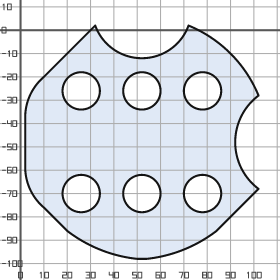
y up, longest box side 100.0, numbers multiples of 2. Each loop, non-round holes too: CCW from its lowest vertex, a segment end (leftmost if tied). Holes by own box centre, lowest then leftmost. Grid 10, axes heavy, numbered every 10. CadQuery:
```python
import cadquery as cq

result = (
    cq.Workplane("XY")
    .moveTo(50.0, -98.0)
    .lineTo(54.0, -98.0)
    .threePointArc((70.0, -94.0), (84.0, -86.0))
    .lineTo(102.0, -68.0)
    .threePointArc((92.0, -48.0), (102.0, -28.0))
    .threePointArc((90.0, -10.0), (72.0, 2.0))
    .threePointArc((52.0, -12.0), (32.0, 2.0))
    .lineTo(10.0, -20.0)
    .threePointArc((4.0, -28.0), (2.0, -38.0))
    .lineTo(2.0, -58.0)
    .threePointArc((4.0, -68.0), (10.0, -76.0))
    .lineTo(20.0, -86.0)
    .threePointArc((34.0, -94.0), (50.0, -98.0))
    .close()
    .moveTo(26.0, -70.0)
    .circle(8.0)
    .moveTo(52.0, -70.0)
    .circle(8.0)
    .moveTo(78.0, -70.0)
    .circle(8.0)
    .moveTo(26.0, -26.0)
    .circle(8.0)
    .moveTo(52.0, -26.0)
    .circle(8.0)
    .moveTo(78.0, -26.0)
    .circle(8.0)
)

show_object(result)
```